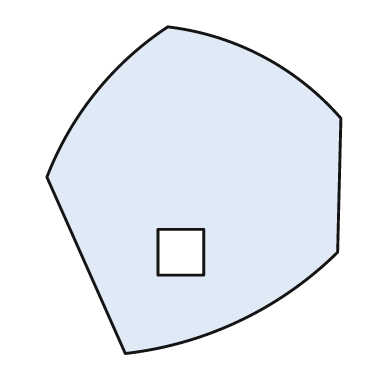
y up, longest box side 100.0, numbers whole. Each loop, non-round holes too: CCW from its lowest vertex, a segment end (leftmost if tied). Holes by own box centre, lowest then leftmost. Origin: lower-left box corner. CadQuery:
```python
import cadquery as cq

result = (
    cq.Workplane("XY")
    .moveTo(24.0, 0.0)
    .threePointArc((59.0, 10.0), (89.0, 31.0))
    .lineTo(90.0, 72.0)
    .threePointArc((66.0, 91.0), (37.0, 100.0))
    .threePointArc((15.0, 80.0), (0.0, 54.0))
    .close()
    .moveTo(34.0, 24.0)
    .lineTo(48.0, 24.0)
    .lineTo(48.0, 38.0)
    .lineTo(34.0, 38.0)
    .close()
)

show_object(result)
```